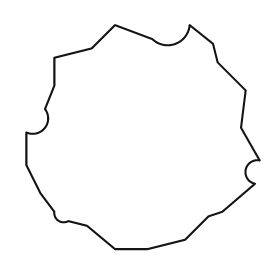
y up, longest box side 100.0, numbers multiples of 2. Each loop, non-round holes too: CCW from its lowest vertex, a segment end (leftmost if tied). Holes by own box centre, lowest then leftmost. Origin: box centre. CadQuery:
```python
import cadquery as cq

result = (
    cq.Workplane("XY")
    .moveTo(-12.0, -48.0)
    .lineTo(2.0, -48.0)
    .lineTo(18.0, -44.0)
    .lineTo(28.0, -34.0)
    .lineTo(34.0, -32.0)
    .lineTo(48.0, -20.0)
    .threePointArc((44.0, -14.0), (50.0, -10.0))
    .lineTo(42.0, 4.0)
    .lineTo(44.0, 20.0)
    .lineTo(32.0, 32.0)
    .lineTo(30.0, 40.0)
    .lineTo(20.0, 48.0)
    .threePointArc((14.0, 40.0), (4.0, 42.0))
    .lineTo(-12.0, 48.0)
    .lineTo(-22.0, 38.0)
    .lineTo(-38.0, 34.0)
    .lineTo(-38.0, 22.0)
    .lineTo(-42.0, 12.0)
    .threePointArc((-42.0, 4.0), (-50.0, 2.0))
    .lineTo(-50.0, -12.0)
    .lineTo(-44.0, -24.0)
    .lineTo(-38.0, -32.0)
    .threePointArc((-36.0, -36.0), (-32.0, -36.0))
    .lineTo(-24.0, -38.0)
    .close()
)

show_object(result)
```